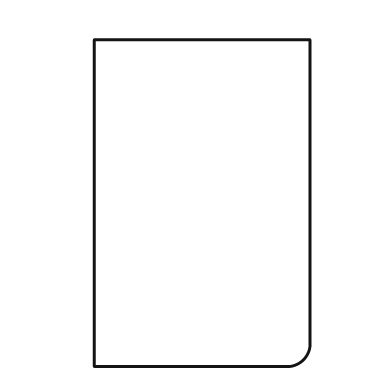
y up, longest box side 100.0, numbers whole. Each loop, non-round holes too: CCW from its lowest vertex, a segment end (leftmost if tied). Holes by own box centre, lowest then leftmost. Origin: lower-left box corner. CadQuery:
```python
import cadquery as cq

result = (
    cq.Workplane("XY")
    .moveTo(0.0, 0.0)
    .lineTo(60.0, 0.0)
    .threePointArc((64.0, 2.0), (66.0, 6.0))
    .lineTo(66.0, 100.0)
    .lineTo(0.0, 100.0)
    .close()
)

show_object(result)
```